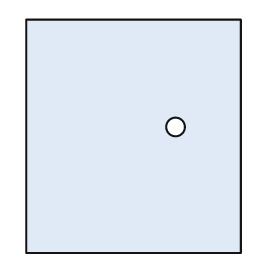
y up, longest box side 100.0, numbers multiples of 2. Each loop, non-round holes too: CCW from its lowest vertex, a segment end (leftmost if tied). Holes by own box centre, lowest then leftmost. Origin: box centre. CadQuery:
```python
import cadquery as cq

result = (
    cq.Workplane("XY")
    .moveTo(-46.0, -50.0)
    .lineTo(46.0, -50.0)
    .lineTo(46.0, 50.0)
    .lineTo(-46.0, 50.0)
    .close()
    .moveTo(18.0, 4.0)
    .circle(4.0)
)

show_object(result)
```